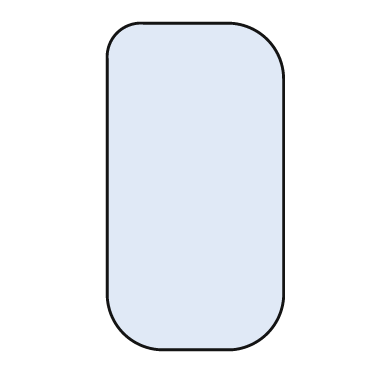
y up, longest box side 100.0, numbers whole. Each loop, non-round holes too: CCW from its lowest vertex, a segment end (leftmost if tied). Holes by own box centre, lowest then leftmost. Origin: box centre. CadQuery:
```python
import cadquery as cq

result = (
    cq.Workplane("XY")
    .moveTo(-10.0, -50.0)
    .lineTo(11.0, -50.0)
    .threePointArc((22.0, -45.0), (27.0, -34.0))
    .lineTo(27.0, 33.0)
    .threePointArc((22.0, 45.0), (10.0, 50.0))
    .lineTo(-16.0, 50.0)
    .threePointArc((-24.0, 47.0), (-27.0, 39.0))
    .lineTo(-27.0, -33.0)
    .threePointArc((-22.0, -45.0), (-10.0, -50.0))
    .close()
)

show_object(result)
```